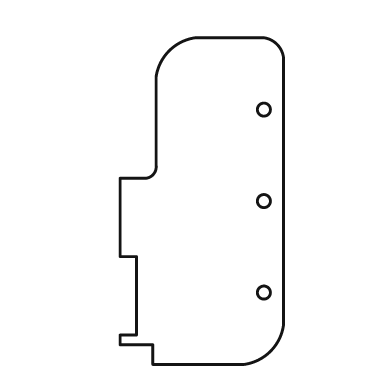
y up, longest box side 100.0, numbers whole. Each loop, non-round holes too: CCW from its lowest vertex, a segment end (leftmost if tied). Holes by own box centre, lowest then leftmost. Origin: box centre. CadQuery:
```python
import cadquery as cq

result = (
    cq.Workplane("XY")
    .moveTo(-15.0, -50.0)
    .lineTo(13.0, -50.0)
    .threePointArc((21.0, -46.0), (25.0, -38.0))
    .lineTo(25.0, 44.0)
    .threePointArc((23.0, 48.0), (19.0, 50.0))
    .lineTo(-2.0, 50.0)
    .threePointArc((-10.0, 46.0), (-14.0, 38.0))
    .lineTo(-14.0, 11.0)
    .threePointArc((-15.0, 8.0), (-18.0, 7.0))
    .lineTo(-25.0, 7.0)
    .lineTo(-25.0, -17.0)
    .lineTo(-20.0, -17.0)
    .lineTo(-20.0, -41.0)
    .lineTo(-25.0, -41.0)
    .lineTo(-25.0, -44.0)
    .lineTo(-15.0, -44.0)
    .close()
    .moveTo(19.0, -28.0)
    .circle(2.0)
    .moveTo(19.0, 0.0)
    .circle(2.0)
    .moveTo(19.0, 28.0)
    .circle(2.0)
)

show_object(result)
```